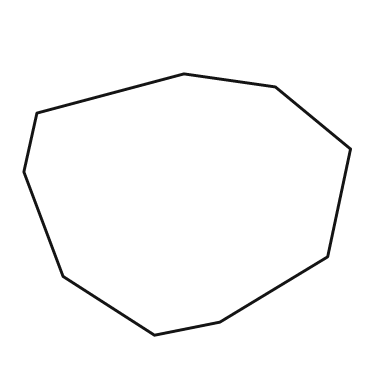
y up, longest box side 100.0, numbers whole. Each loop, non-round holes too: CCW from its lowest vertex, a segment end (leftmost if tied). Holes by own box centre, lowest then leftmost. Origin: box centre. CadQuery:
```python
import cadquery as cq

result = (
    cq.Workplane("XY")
    .moveTo(-10.0, -40.0)
    .lineTo(10.0, -36.0)
    .lineTo(43.0, -16.0)
    .lineTo(50.0, 17.0)
    .lineTo(27.0, 36.0)
    .lineTo(-1.0, 40.0)
    .lineTo(-46.0, 28.0)
    .lineTo(-50.0, 10.0)
    .lineTo(-38.0, -22.0)
    .close()
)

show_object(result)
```